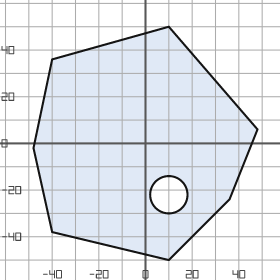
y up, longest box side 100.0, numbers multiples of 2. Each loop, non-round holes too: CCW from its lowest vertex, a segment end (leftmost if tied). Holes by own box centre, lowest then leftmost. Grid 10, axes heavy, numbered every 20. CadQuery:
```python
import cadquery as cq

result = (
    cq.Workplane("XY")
    .moveTo(10.0, -50.0)
    .lineTo(36.0, -24.0)
    .lineTo(48.0, 6.0)
    .lineTo(10.0, 50.0)
    .lineTo(-40.0, 36.0)
    .lineTo(-48.0, -2.0)
    .lineTo(-40.0, -38.0)
    .close()
    .moveTo(10.0, -22.0)
    .circle(8.0)
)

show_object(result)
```